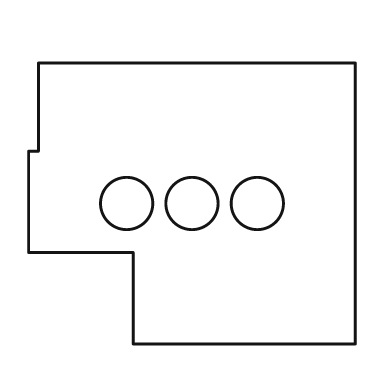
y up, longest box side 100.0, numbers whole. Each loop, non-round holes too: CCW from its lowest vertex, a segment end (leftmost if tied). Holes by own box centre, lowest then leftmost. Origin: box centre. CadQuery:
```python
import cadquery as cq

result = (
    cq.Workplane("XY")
    .moveTo(-18.0, -43.0)
    .lineTo(50.0, -43.0)
    .lineTo(50.0, 43.0)
    .lineTo(-47.0, 43.0)
    .lineTo(-47.0, 16.0)
    .lineTo(-50.0, 16.0)
    .lineTo(-50.0, -15.0)
    .lineTo(-18.0, -15.0)
    .close()
    .moveTo(-20.0, 0.0)
    .circle(8.0)
    .moveTo(0.0, 0.0)
    .circle(8.0)
    .moveTo(20.0, 0.0)
    .circle(8.0)
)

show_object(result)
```